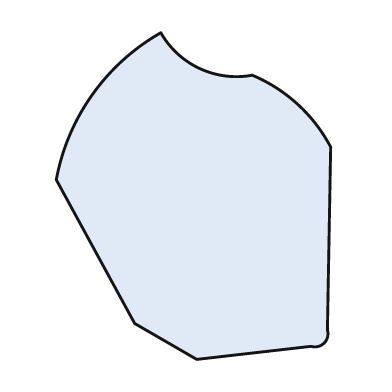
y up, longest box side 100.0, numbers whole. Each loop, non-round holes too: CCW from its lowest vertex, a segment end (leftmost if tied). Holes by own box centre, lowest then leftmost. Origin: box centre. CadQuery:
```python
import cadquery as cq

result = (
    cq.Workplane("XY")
    .moveTo(1.0, -50.0)
    .lineTo(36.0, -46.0)
    .threePointArc((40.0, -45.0), (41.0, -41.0))
    .lineTo(42.0, 15.0)
    .threePointArc((32.0, 28.0), (18.0, 37.0))
    .threePointArc((2.0, 39.0), (-10.0, 50.0))
    .threePointArc((-31.0, 31.0), (-42.0, 5.0))
    .lineTo(-18.0, -39.0)
    .close()
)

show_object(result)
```